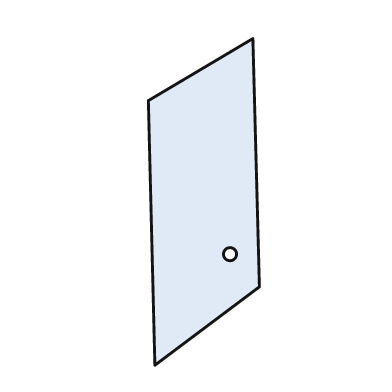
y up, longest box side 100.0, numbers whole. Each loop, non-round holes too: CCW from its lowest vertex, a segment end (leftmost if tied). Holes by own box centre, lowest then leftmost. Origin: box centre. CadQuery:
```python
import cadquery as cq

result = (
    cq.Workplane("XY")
    .moveTo(-15.0, -50.0)
    .lineTo(17.0, -26.0)
    .lineTo(15.0, 50.0)
    .lineTo(-17.0, 31.0)
    .close()
    .moveTo(8.0, -16.0)
    .circle(2.0)
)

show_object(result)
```